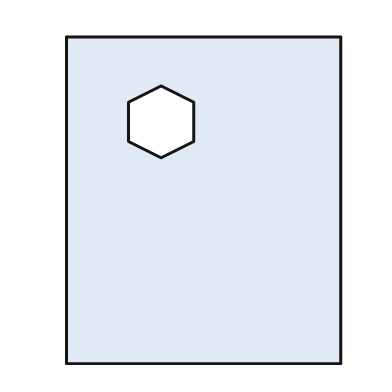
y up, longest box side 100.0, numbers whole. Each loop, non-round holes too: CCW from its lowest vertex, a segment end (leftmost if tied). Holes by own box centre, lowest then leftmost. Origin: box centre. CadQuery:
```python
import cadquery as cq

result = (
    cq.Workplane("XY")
    .moveTo(-42.0, -50.0)
    .lineTo(42.0, -50.0)
    .lineTo(42.0, 50.0)
    .lineTo(-42.0, 50.0)
    .close()
    .moveTo(-13.0, 13.0)
    .lineTo(-3.0, 18.0)
    .lineTo(-3.0, 30.0)
    .lineTo(-13.0, 35.0)
    .lineTo(-23.0, 30.0)
    .lineTo(-23.0, 18.0)
    .close()
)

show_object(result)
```